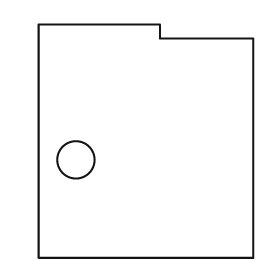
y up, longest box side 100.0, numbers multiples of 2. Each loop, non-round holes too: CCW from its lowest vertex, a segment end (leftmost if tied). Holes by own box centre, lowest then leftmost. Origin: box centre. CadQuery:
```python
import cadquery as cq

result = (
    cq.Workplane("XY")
    .moveTo(-46.0, -50.0)
    .lineTo(46.0, -50.0)
    .lineTo(46.0, 44.0)
    .lineTo(6.0, 44.0)
    .lineTo(6.0, 50.0)
    .lineTo(-46.0, 50.0)
    .close()
    .moveTo(-30.0, -8.0)
    .circle(8.0)
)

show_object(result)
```